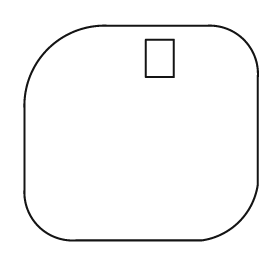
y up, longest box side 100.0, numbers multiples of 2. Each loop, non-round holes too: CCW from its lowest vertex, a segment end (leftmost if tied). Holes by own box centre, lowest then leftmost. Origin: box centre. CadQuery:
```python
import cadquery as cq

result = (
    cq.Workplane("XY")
    .moveTo(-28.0, -46.0)
    .lineTo(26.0, -46.0)
    .threePointArc((42.0, -38.0), (50.0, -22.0))
    .lineTo(50.0, 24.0)
    .threePointArc((44.0, 40.0), (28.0, 46.0))
    .lineTo(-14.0, 46.0)
    .threePointArc((-40.0, 36.0), (-50.0, 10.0))
    .lineTo(-50.0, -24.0)
    .threePointArc((-44.0, -40.0), (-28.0, -46.0))
    .close()
    .moveTo(2.0, 24.0)
    .lineTo(14.0, 24.0)
    .lineTo(14.0, 40.0)
    .lineTo(2.0, 40.0)
    .close()
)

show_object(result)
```